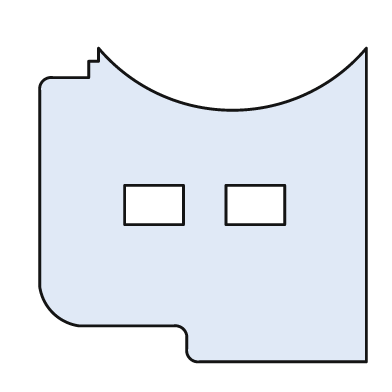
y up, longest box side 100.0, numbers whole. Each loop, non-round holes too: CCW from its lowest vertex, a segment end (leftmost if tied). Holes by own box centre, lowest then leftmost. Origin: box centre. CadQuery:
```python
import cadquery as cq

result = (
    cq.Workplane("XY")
    .moveTo(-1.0, -48.0)
    .lineTo(50.0, -48.0)
    .lineTo(50.0, 48.0)
    .threePointArc((9.0, 29.0), (-32.0, 48.0))
    .lineTo(-32.0, 44.0)
    .lineTo(-35.0, 44.0)
    .lineTo(-35.0, 39.0)
    .lineTo(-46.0, 39.0)
    .threePointArc((-49.0, 38.0), (-50.0, 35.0))
    .lineTo(-50.0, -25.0)
    .threePointArc((-46.0, -33.0), (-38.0, -37.0))
    .lineTo(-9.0, -37.0)
    .threePointArc((-6.0, -38.0), (-5.0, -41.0))
    .lineTo(-5.0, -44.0)
    .threePointArc((-4.0, -47.0), (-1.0, -48.0))
    .close()
    .moveTo(-24.0, -6.0)
    .lineTo(-6.0, -6.0)
    .lineTo(-6.0, 6.0)
    .lineTo(-24.0, 6.0)
    .close()
    .moveTo(7.0, -6.0)
    .lineTo(25.0, -6.0)
    .lineTo(25.0, 6.0)
    .lineTo(7.0, 6.0)
    .close()
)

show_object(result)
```